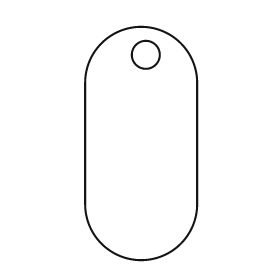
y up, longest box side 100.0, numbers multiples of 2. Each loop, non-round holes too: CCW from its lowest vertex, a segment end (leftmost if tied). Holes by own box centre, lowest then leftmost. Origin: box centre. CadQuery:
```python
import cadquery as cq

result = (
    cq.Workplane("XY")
    .moveTo(-24.0, -26.0)
    .threePointArc((0.0, -50.0), (24.0, -26.0))
    .lineTo(24.0, 26.0)
    .threePointArc((0.0, 50.0), (-24.0, 26.0))
    .close()
    .moveTo(2.0, 38.0)
    .circle(6.0)
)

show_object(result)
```